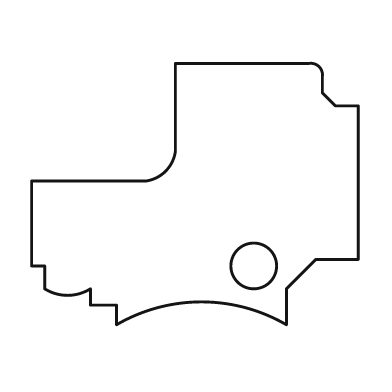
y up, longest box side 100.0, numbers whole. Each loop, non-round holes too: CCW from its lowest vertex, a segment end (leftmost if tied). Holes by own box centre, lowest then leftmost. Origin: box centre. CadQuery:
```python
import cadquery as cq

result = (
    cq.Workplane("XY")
    .moveTo(-24.0, -40.0)
    .threePointArc((2.0, -33.0), (28.0, -40.0))
    .lineTo(28.0, -29.0)
    .lineTo(37.0, -20.0)
    .lineTo(50.0, -20.0)
    .lineTo(50.0, 27.0)
    .lineTo(43.0, 27.0)
    .lineTo(39.0, 31.0)
    .lineTo(39.0, 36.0)
    .threePointArc((38.0, 39.0), (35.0, 40.0))
    .lineTo(-6.0, 40.0)
    .lineTo(-6.0, 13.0)
    .threePointArc((-9.0, 7.0), (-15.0, 4.0))
    .lineTo(-50.0, 4.0)
    .lineTo(-50.0, -22.0)
    .lineTo(-46.0, -22.0)
    .lineTo(-46.0, -29.0)
    .threePointArc((-39.0, -31.0), (-32.0, -29.0))
    .lineTo(-32.0, -34.0)
    .lineTo(-24.0, -34.0)
    .close()
    .moveTo(18.0, -22.0)
    .circle(7.0)
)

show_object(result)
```